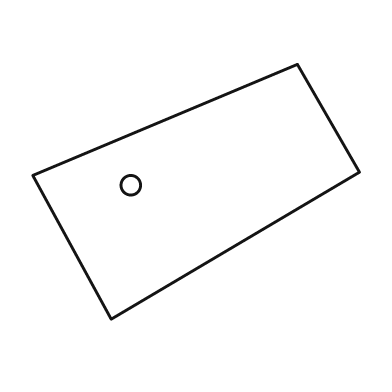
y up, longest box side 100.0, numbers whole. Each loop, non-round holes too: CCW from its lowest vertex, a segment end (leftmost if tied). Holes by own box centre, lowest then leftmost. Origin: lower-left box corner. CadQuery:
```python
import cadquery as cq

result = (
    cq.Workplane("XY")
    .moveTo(24.0, 0.0)
    .lineTo(100.0, 45.0)
    .lineTo(81.0, 78.0)
    .lineTo(0.0, 44.0)
    .close()
    .moveTo(30.0, 41.0)
    .circle(3.0)
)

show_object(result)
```